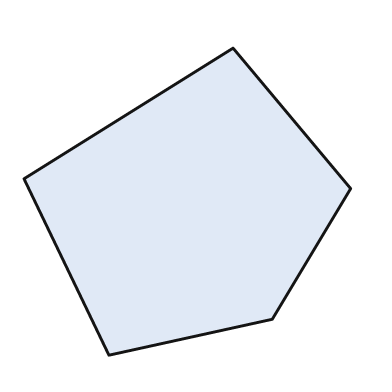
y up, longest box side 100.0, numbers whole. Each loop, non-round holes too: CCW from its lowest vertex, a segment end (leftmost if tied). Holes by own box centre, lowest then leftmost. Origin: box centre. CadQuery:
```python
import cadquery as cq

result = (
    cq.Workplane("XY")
    .moveTo(-24.0, -47.0)
    .lineTo(26.0, -36.0)
    .lineTo(50.0, 4.0)
    .lineTo(14.0, 47.0)
    .lineTo(-50.0, 7.0)
    .close()
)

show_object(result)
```